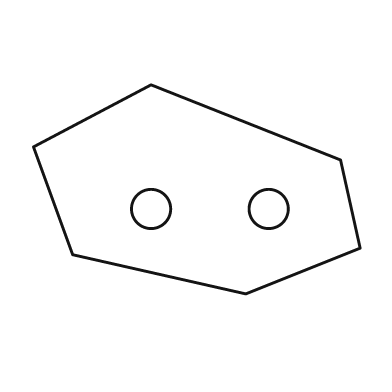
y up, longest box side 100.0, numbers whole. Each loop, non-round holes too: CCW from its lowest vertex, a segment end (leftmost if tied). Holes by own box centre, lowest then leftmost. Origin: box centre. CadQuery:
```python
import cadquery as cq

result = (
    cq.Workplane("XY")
    .moveTo(15.0, -32.0)
    .lineTo(50.0, -18.0)
    .lineTo(44.0, 9.0)
    .lineTo(-14.0, 32.0)
    .lineTo(-50.0, 13.0)
    .lineTo(-38.0, -20.0)
    .close()
    .moveTo(-14.0, -6.0)
    .circle(6.0)
    .moveTo(22.0, -6.0)
    .circle(6.0)
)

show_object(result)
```